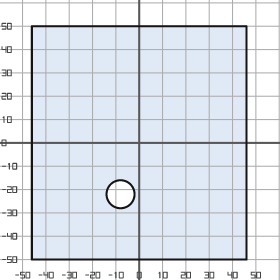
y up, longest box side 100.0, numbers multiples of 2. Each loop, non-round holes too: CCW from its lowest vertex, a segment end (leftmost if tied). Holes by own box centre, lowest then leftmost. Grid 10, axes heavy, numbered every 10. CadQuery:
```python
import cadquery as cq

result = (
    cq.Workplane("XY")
    .moveTo(-46.0, -50.0)
    .lineTo(46.0, -50.0)
    .lineTo(46.0, 50.0)
    .lineTo(-46.0, 50.0)
    .close()
    .moveTo(-8.0, -22.0)
    .circle(6.0)
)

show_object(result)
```